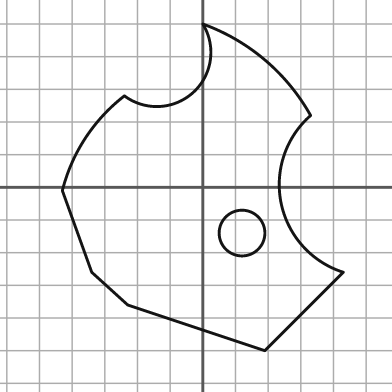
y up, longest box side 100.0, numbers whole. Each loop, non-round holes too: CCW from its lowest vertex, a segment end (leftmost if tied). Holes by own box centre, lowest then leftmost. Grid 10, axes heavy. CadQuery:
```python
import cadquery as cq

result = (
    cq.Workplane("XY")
    .moveTo(19.0, -50.0)
    .lineTo(43.0, -26.0)
    .threePointArc((24.0, -5.0), (33.0, 22.0))
    .threePointArc((19.0, 39.0), (0.0, 50.0))
    .threePointArc((-3.0, 29.0), (-24.0, 28.0))
    .threePointArc((-36.0, 15.0), (-43.0, -1.0))
    .lineTo(-34.0, -26.0)
    .lineTo(-23.0, -36.0)
    .close()
    .moveTo(12.0, -14.0)
    .circle(7.0)
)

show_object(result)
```